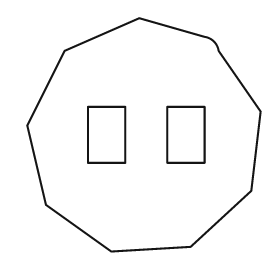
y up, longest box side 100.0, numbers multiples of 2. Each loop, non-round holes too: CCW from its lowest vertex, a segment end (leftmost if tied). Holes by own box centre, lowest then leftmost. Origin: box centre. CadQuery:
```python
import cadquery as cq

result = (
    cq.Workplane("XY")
    .moveTo(-14.0, -50.0)
    .lineTo(20.0, -48.0)
    .lineTo(46.0, -24.0)
    .lineTo(50.0, 10.0)
    .lineTo(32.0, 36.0)
    .threePointArc((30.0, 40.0), (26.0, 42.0))
    .lineTo(-2.0, 50.0)
    .lineTo(-34.0, 36.0)
    .lineTo(-50.0, 4.0)
    .lineTo(-42.0, -30.0)
    .close()
    .moveTo(-24.0, -12.0)
    .lineTo(-8.0, -12.0)
    .lineTo(-8.0, 12.0)
    .lineTo(-24.0, 12.0)
    .close()
    .moveTo(10.0, -12.0)
    .lineTo(26.0, -12.0)
    .lineTo(26.0, 12.0)
    .lineTo(10.0, 12.0)
    .close()
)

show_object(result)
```